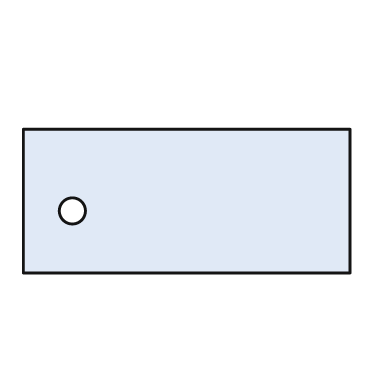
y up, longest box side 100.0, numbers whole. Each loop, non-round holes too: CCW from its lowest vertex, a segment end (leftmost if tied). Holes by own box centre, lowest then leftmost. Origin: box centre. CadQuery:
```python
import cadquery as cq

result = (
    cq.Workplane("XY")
    .moveTo(-50.0, -22.0)
    .lineTo(50.0, -22.0)
    .lineTo(50.0, 22.0)
    .lineTo(-50.0, 22.0)
    .close()
    .moveTo(-35.0, -3.0)
    .circle(4.0)
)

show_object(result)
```